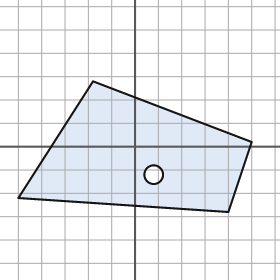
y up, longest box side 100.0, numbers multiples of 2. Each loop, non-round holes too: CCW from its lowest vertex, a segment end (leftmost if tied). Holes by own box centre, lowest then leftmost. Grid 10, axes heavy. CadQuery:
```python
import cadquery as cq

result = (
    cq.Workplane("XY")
    .moveTo(40.0, -28.0)
    .lineTo(50.0, 2.0)
    .lineTo(-18.0, 28.0)
    .lineTo(-50.0, -22.0)
    .close()
    .moveTo(8.0, -12.0)
    .circle(4.0)
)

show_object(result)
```